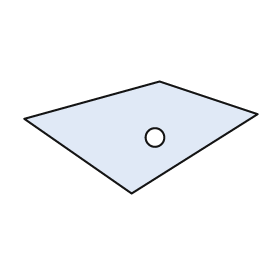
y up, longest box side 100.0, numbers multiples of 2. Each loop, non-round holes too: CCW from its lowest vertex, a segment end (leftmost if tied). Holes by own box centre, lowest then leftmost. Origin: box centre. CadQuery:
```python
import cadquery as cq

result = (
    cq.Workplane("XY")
    .moveTo(-4.0, -24.0)
    .lineTo(50.0, 10.0)
    .lineTo(8.0, 24.0)
    .lineTo(-50.0, 8.0)
    .close()
    .moveTo(6.0, 0.0)
    .circle(4.0)
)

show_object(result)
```